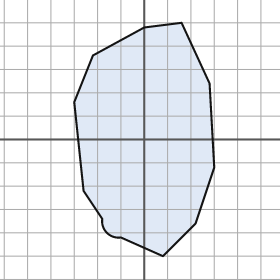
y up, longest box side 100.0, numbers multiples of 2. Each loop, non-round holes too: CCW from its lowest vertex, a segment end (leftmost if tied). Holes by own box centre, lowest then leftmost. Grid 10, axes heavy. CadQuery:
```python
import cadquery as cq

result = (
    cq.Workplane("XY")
    .moveTo(8.0, -50.0)
    .lineTo(22.0, -36.0)
    .lineTo(30.0, -12.0)
    .lineTo(28.0, 24.0)
    .lineTo(16.0, 50.0)
    .lineTo(0.0, 48.0)
    .lineTo(-22.0, 36.0)
    .lineTo(-30.0, 16.0)
    .lineTo(-26.0, -22.0)
    .lineTo(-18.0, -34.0)
    .threePointArc((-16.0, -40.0), (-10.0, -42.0))
    .close()
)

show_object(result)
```